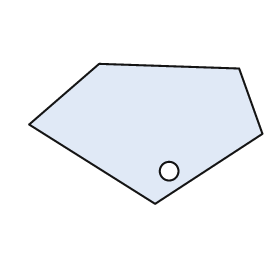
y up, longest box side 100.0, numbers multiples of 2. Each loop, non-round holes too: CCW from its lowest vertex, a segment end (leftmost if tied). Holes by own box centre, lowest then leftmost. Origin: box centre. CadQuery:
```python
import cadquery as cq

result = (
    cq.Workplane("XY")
    .moveTo(4.0, -30.0)
    .lineTo(50.0, 0.0)
    .lineTo(40.0, 28.0)
    .lineTo(-20.0, 30.0)
    .lineTo(-50.0, 4.0)
    .close()
    .moveTo(10.0, -16.0)
    .circle(4.0)
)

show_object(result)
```